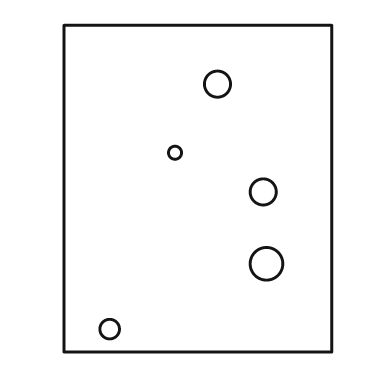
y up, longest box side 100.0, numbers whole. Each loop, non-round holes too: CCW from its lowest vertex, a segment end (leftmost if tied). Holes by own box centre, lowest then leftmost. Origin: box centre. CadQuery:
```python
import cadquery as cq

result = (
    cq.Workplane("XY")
    .moveTo(-41.0, -50.0)
    .lineTo(41.0, -50.0)
    .lineTo(41.0, 50.0)
    .lineTo(-41.0, 50.0)
    .close()
    .moveTo(-27.0, -43.0)
    .circle(3.0)
    .moveTo(21.0, -23.0)
    .circle(5.0)
    .moveTo(20.0, -1.0)
    .circle(4.0)
    .moveTo(-7.0, 11.0)
    .circle(2.0)
    .moveTo(6.0, 32.0)
    .circle(4.0)
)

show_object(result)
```